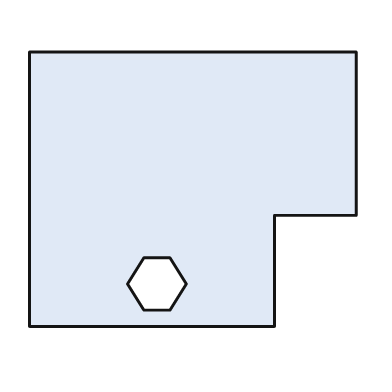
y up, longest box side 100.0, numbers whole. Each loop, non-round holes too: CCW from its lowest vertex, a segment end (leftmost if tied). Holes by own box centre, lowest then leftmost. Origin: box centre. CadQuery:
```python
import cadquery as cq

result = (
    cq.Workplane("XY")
    .moveTo(-50.0, -42.0)
    .lineTo(25.0, -42.0)
    .lineTo(25.0, -8.0)
    .lineTo(50.0, -8.0)
    .lineTo(50.0, 42.0)
    .lineTo(-50.0, 42.0)
    .close()
    .moveTo(-15.0, -37.0)
    .lineTo(-7.0, -37.0)
    .lineTo(-2.0, -29.0)
    .lineTo(-7.0, -21.0)
    .lineTo(-15.0, -21.0)
    .lineTo(-20.0, -29.0)
    .close()
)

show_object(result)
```